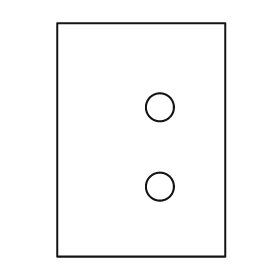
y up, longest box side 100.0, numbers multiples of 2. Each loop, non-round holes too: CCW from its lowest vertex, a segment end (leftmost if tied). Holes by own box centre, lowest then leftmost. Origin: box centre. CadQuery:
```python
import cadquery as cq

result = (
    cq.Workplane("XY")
    .moveTo(-36.0, -50.0)
    .lineTo(36.0, -50.0)
    .lineTo(36.0, 50.0)
    .lineTo(-36.0, 50.0)
    .close()
    .moveTo(8.0, -20.0)
    .circle(6.0)
    .moveTo(8.0, 14.0)
    .circle(6.0)
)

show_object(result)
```